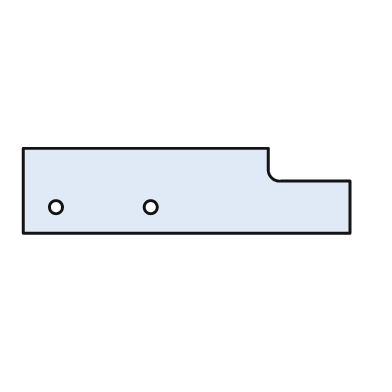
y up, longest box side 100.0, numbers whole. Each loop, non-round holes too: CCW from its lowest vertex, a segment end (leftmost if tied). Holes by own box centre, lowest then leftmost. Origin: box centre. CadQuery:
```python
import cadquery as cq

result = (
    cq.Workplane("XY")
    .moveTo(-50.0, -13.0)
    .lineTo(50.0, -13.0)
    .lineTo(50.0, 3.0)
    .lineTo(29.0, 3.0)
    .threePointArc((26.0, 4.0), (25.0, 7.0))
    .lineTo(25.0, 13.0)
    .lineTo(-50.0, 13.0)
    .close()
    .moveTo(-40.0, -5.0)
    .circle(2.0)
    .moveTo(-11.0, -5.0)
    .circle(2.0)
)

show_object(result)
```